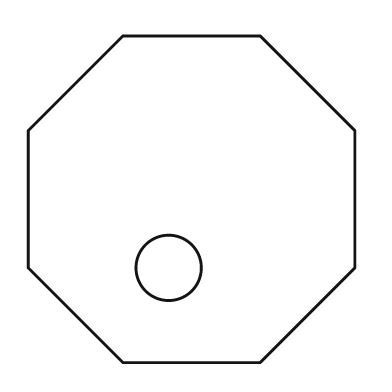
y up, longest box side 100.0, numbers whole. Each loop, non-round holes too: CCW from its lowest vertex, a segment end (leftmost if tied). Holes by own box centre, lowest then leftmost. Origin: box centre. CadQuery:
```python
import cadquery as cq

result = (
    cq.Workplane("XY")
    .moveTo(-21.0, -50.0)
    .lineTo(21.0, -50.0)
    .lineTo(50.0, -21.0)
    .lineTo(50.0, 21.0)
    .lineTo(21.0, 50.0)
    .lineTo(-21.0, 50.0)
    .lineTo(-50.0, 21.0)
    .lineTo(-50.0, -21.0)
    .close()
    .moveTo(-7.0, -21.0)
    .circle(10.0)
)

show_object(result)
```